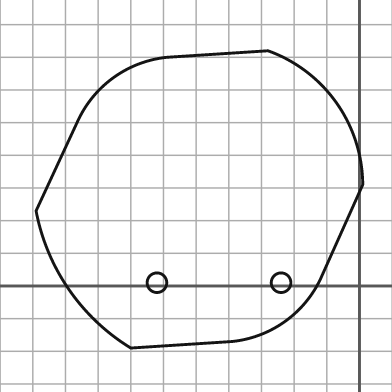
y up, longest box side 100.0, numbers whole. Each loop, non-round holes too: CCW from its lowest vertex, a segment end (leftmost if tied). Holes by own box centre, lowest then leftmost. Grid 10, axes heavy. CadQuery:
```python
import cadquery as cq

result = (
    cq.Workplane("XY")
    .moveTo(-70.0, -19.0)
    .lineTo(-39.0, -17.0)
    .threePointArc((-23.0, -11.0), (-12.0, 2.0))
    .lineTo(1.0, 31.0)
    .threePointArc((-7.0, 56.0), (-28.0, 72.0))
    .lineTo(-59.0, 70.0)
    .threePointArc((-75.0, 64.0), (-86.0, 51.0))
    .lineTo(-99.0, 23.0)
    .threePointArc((-89.0, -1.0), (-70.0, -19.0))
    .close()
    .moveTo(-62.0, 1.0)
    .circle(3.0)
    .moveTo(-24.0, 1.0)
    .circle(3.0)
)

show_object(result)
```